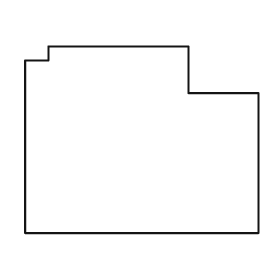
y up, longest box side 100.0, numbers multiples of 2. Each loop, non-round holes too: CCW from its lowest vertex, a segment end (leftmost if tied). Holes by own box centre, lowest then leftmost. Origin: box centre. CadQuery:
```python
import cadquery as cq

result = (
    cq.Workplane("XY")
    .moveTo(-50.0, -40.0)
    .lineTo(50.0, -40.0)
    .lineTo(50.0, 20.0)
    .lineTo(20.0, 20.0)
    .lineTo(20.0, 40.0)
    .lineTo(-40.0, 40.0)
    .lineTo(-40.0, 34.0)
    .lineTo(-50.0, 34.0)
    .close()
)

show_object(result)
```